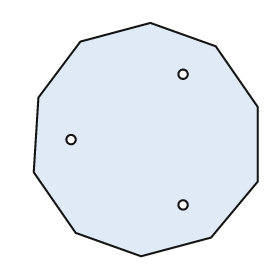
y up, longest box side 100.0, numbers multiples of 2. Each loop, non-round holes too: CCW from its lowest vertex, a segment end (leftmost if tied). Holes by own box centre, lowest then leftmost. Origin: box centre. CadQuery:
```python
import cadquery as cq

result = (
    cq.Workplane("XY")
    .moveTo(-2.0, -50.0)
    .lineTo(28.0, -42.0)
    .lineTo(48.0, -18.0)
    .lineTo(48.0, 14.0)
    .lineTo(30.0, 40.0)
    .lineTo(2.0, 50.0)
    .lineTo(-28.0, 42.0)
    .lineTo(-46.0, 18.0)
    .lineTo(-48.0, -14.0)
    .lineTo(-30.0, -40.0)
    .close()
    .moveTo(16.0, -28.0)
    .circle(2.0)
    .moveTo(-32.0, 0.0)
    .circle(2.0)
    .moveTo(16.0, 28.0)
    .circle(2.0)
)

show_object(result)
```